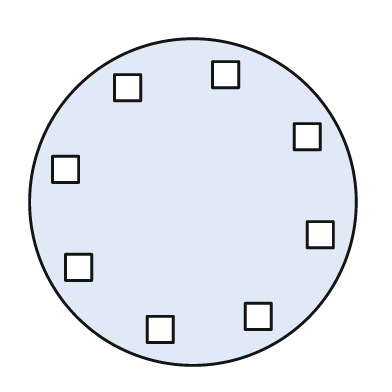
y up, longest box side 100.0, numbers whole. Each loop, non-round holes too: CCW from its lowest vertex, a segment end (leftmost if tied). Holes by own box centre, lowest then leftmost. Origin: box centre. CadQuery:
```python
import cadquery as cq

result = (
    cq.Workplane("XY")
    .moveTo(0.0, 0.0)
    .circle(50.0)
    .moveTo(-14.0, -43.0)
    .lineTo(-6.0, -43.0)
    .lineTo(-6.0, -35.0)
    .lineTo(-14.0, -35.0)
    .close()
    .moveTo(16.0, -39.0)
    .lineTo(24.0, -39.0)
    .lineTo(24.0, -31.0)
    .lineTo(16.0, -31.0)
    .close()
    .moveTo(-39.0, -24.0)
    .lineTo(-31.0, -24.0)
    .lineTo(-31.0, -16.0)
    .lineTo(-39.0, -16.0)
    .close()
    .moveTo(35.0, -14.0)
    .lineTo(43.0, -14.0)
    .lineTo(43.0, -6.0)
    .lineTo(35.0, -6.0)
    .close()
    .moveTo(-43.0, 6.0)
    .lineTo(-35.0, 6.0)
    .lineTo(-35.0, 14.0)
    .lineTo(-43.0, 14.0)
    .close()
    .moveTo(31.0, 16.0)
    .lineTo(39.0, 16.0)
    .lineTo(39.0, 24.0)
    .lineTo(31.0, 24.0)
    .close()
    .moveTo(-24.0, 31.0)
    .lineTo(-16.0, 31.0)
    .lineTo(-16.0, 39.0)
    .lineTo(-24.0, 39.0)
    .close()
    .moveTo(6.0, 35.0)
    .lineTo(14.0, 35.0)
    .lineTo(14.0, 43.0)
    .lineTo(6.0, 43.0)
    .close()
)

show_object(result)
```